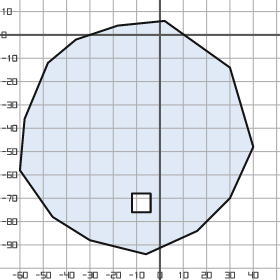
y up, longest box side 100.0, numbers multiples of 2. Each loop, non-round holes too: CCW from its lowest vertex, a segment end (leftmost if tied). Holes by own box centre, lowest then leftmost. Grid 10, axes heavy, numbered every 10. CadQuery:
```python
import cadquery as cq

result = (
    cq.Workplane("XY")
    .moveTo(-6.0, -94.0)
    .lineTo(16.0, -84.0)
    .lineTo(30.0, -70.0)
    .lineTo(40.0, -48.0)
    .lineTo(30.0, -14.0)
    .lineTo(2.0, 6.0)
    .lineTo(-18.0, 4.0)
    .lineTo(-36.0, -2.0)
    .lineTo(-48.0, -12.0)
    .lineTo(-58.0, -36.0)
    .lineTo(-60.0, -58.0)
    .lineTo(-46.0, -78.0)
    .lineTo(-30.0, -88.0)
    .close()
    .moveTo(-12.0, -76.0)
    .lineTo(-4.0, -76.0)
    .lineTo(-4.0, -68.0)
    .lineTo(-12.0, -68.0)
    .close()
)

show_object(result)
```